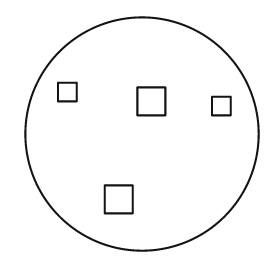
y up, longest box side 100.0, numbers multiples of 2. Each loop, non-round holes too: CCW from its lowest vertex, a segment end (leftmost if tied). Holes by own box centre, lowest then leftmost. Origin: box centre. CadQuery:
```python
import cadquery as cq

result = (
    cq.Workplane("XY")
    .moveTo(0.0, 0.0)
    .circle(50.0)
    .moveTo(-16.0, -34.0)
    .lineTo(-4.0, -34.0)
    .lineTo(-4.0, -22.0)
    .lineTo(-16.0, -22.0)
    .close()
    .moveTo(30.0, 8.0)
    .lineTo(38.0, 8.0)
    .lineTo(38.0, 16.0)
    .lineTo(30.0, 16.0)
    .close()
    .moveTo(-2.0, 8.0)
    .lineTo(10.0, 8.0)
    .lineTo(10.0, 20.0)
    .lineTo(-2.0, 20.0)
    .close()
    .moveTo(-36.0, 14.0)
    .lineTo(-28.0, 14.0)
    .lineTo(-28.0, 22.0)
    .lineTo(-36.0, 22.0)
    .close()
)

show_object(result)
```